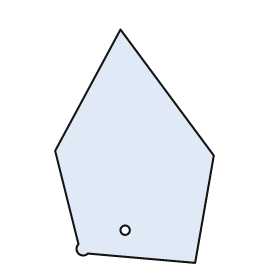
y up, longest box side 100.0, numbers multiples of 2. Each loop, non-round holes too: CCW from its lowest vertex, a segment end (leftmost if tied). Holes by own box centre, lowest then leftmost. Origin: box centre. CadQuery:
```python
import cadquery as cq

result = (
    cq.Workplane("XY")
    .moveTo(26.0, -50.0)
    .lineTo(34.0, -4.0)
    .lineTo(-6.0, 50.0)
    .lineTo(-34.0, -2.0)
    .lineTo(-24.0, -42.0)
    .threePointArc((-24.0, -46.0), (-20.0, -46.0))
    .close()
    .moveTo(-4.0, -36.0)
    .circle(2.0)
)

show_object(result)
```